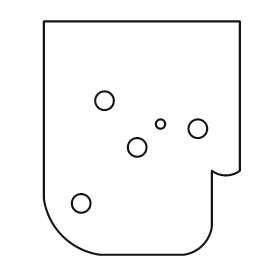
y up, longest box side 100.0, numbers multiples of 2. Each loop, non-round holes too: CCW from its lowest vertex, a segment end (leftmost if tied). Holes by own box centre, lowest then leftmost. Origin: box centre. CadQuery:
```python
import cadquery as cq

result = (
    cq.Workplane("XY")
    .moveTo(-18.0, -50.0)
    .lineTo(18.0, -50.0)
    .threePointArc((26.0, -46.0), (30.0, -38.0))
    .lineTo(30.0, -14.0)
    .threePointArc((36.0, -16.0), (42.0, -14.0))
    .lineTo(42.0, 50.0)
    .lineTo(-42.0, 50.0)
    .lineTo(-42.0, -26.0)
    .threePointArc((-34.0, -42.0), (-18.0, -50.0))
    .close()
    .moveTo(-26.0, -28.0)
    .circle(4.0)
    .moveTo(-2.0, -4.0)
    .circle(4.0)
    .moveTo(24.0, 4.0)
    .circle(4.0)
    .moveTo(8.0, 6.0)
    .circle(2.0)
    .moveTo(-16.0, 16.0)
    .circle(4.0)
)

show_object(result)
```